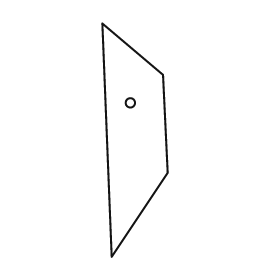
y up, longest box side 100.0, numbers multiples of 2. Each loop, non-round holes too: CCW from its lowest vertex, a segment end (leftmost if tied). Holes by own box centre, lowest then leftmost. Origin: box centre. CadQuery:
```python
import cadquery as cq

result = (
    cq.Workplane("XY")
    .moveTo(-10.0, -50.0)
    .lineTo(14.0, -14.0)
    .lineTo(12.0, 28.0)
    .lineTo(-14.0, 50.0)
    .close()
    .moveTo(-2.0, 16.0)
    .circle(2.0)
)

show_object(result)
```